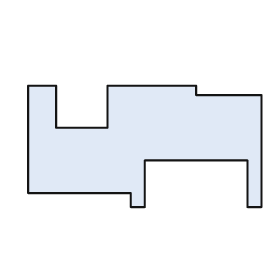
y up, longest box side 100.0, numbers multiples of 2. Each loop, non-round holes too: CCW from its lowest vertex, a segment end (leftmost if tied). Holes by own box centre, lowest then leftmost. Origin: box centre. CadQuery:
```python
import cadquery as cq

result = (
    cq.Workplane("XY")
    .moveTo(-6.0, -26.0)
    .lineTo(0.0, -26.0)
    .lineTo(0.0, -6.0)
    .lineTo(44.0, -6.0)
    .lineTo(44.0, -26.0)
    .lineTo(50.0, -26.0)
    .lineTo(50.0, 22.0)
    .lineTo(22.0, 22.0)
    .lineTo(22.0, 26.0)
    .lineTo(-16.0, 26.0)
    .lineTo(-16.0, 8.0)
    .lineTo(-38.0, 8.0)
    .lineTo(-38.0, 26.0)
    .lineTo(-50.0, 26.0)
    .lineTo(-50.0, -20.0)
    .lineTo(-6.0, -20.0)
    .close()
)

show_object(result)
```